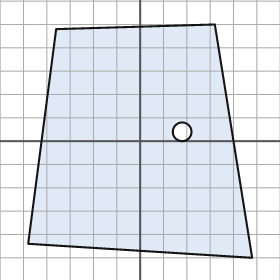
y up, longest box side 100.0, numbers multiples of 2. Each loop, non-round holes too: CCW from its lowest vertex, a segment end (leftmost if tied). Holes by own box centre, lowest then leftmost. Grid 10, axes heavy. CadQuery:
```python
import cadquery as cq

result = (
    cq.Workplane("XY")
    .moveTo(48.0, -50.0)
    .lineTo(32.0, 50.0)
    .lineTo(-36.0, 48.0)
    .lineTo(-48.0, -44.0)
    .close()
    .moveTo(18.0, 4.0)
    .circle(4.0)
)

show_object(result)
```